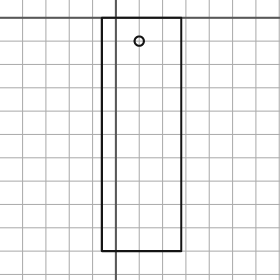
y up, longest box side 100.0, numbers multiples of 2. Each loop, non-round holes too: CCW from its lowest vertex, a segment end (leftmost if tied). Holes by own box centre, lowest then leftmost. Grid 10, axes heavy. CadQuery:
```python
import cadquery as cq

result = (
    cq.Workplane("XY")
    .moveTo(-6.0, -100.0)
    .lineTo(28.0, -100.0)
    .lineTo(28.0, 0.0)
    .lineTo(-6.0, 0.0)
    .close()
    .moveTo(10.0, -10.0)
    .circle(2.0)
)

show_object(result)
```